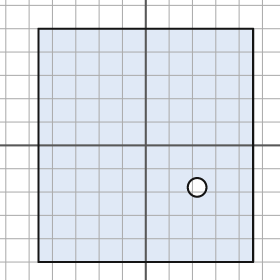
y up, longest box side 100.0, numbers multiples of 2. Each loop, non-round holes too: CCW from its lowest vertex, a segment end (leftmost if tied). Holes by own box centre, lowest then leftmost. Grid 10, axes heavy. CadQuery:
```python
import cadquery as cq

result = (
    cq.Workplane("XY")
    .moveTo(-46.0, -50.0)
    .lineTo(46.0, -50.0)
    .lineTo(46.0, 50.0)
    .lineTo(-46.0, 50.0)
    .close()
    .moveTo(22.0, -18.0)
    .circle(4.0)
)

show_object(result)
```